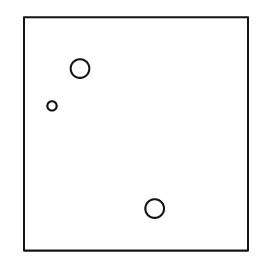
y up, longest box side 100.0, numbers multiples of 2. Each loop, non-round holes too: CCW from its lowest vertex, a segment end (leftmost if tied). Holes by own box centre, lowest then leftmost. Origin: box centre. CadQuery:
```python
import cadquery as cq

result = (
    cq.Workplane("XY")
    .moveTo(-48.0, -50.0)
    .lineTo(48.0, -50.0)
    .lineTo(48.0, 50.0)
    .lineTo(-48.0, 50.0)
    .close()
    .moveTo(8.0, -32.0)
    .circle(4.0)
    .moveTo(-36.0, 12.0)
    .circle(2.0)
    .moveTo(-24.0, 28.0)
    .circle(4.0)
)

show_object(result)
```